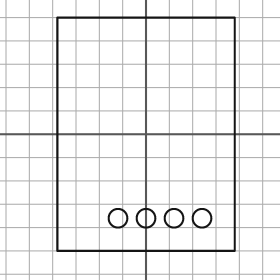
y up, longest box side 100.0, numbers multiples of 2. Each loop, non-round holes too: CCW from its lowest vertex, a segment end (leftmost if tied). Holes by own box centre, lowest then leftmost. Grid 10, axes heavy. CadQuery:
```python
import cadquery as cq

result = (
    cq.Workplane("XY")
    .moveTo(-38.0, -50.0)
    .lineTo(38.0, -50.0)
    .lineTo(38.0, 50.0)
    .lineTo(-38.0, 50.0)
    .close()
    .moveTo(-12.0, -36.0)
    .circle(4.0)
    .moveTo(0.0, -36.0)
    .circle(4.0)
    .moveTo(12.0, -36.0)
    .circle(4.0)
    .moveTo(24.0, -36.0)
    .circle(4.0)
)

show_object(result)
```